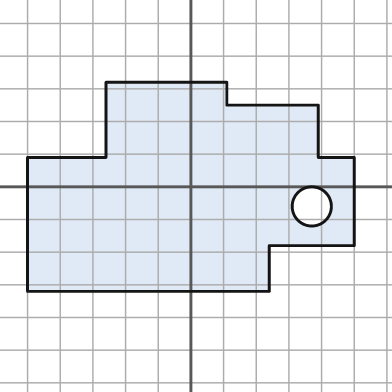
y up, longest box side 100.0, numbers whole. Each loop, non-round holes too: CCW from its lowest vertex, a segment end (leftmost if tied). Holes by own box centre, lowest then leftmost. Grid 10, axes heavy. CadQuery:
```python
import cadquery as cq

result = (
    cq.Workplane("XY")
    .moveTo(-50.0, -32.0)
    .lineTo(24.0, -32.0)
    .lineTo(24.0, -18.0)
    .lineTo(50.0, -18.0)
    .lineTo(50.0, 9.0)
    .lineTo(39.0, 9.0)
    .lineTo(39.0, 25.0)
    .lineTo(11.0, 25.0)
    .lineTo(11.0, 32.0)
    .lineTo(-26.0, 32.0)
    .lineTo(-26.0, 9.0)
    .lineTo(-50.0, 9.0)
    .close()
    .moveTo(37.0, -6.0)
    .circle(6.0)
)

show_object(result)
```